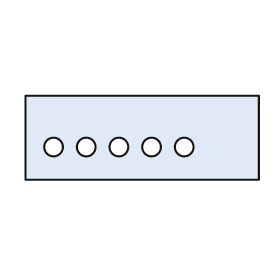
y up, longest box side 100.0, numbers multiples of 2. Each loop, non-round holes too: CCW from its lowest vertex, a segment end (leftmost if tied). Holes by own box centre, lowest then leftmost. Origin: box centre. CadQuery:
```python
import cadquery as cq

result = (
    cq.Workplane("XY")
    .moveTo(-50.0, -18.0)
    .lineTo(50.0, -18.0)
    .lineTo(50.0, 18.0)
    .lineTo(-50.0, 18.0)
    .close()
    .moveTo(-38.0, -4.0)
    .circle(4.0)
    .moveTo(-24.0, -4.0)
    .circle(4.0)
    .moveTo(-10.0, -4.0)
    .circle(4.0)
    .moveTo(4.0, -4.0)
    .circle(4.0)
    .moveTo(18.0, -4.0)
    .circle(4.0)
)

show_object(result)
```